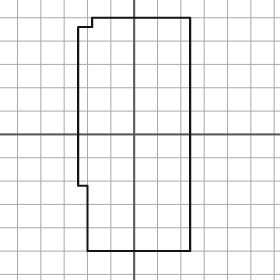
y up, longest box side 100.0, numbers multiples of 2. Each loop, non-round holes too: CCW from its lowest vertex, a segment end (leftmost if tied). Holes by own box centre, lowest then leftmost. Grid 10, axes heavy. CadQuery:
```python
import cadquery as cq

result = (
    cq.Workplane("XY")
    .moveTo(-20.0, -50.0)
    .lineTo(24.0, -50.0)
    .lineTo(24.0, 50.0)
    .lineTo(-18.0, 50.0)
    .lineTo(-18.0, 46.0)
    .lineTo(-24.0, 46.0)
    .lineTo(-24.0, -22.0)
    .lineTo(-20.0, -22.0)
    .close()
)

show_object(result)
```